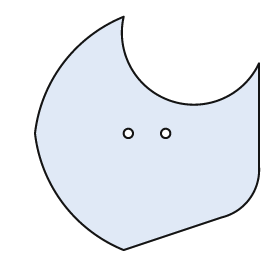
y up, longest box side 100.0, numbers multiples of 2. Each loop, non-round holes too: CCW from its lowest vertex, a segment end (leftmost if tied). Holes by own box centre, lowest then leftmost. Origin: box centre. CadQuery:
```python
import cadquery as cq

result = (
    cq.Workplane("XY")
    .moveTo(-10.0, -50.0)
    .lineTo(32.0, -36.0)
    .threePointArc((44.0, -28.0), (48.0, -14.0))
    .lineTo(48.0, 30.0)
    .threePointArc((10.0, 14.0), (-10.0, 50.0))
    .threePointArc((-36.0, 30.0), (-48.0, 0.0))
    .threePointArc((-36.0, -30.0), (-10.0, -50.0))
    .close()
    .moveTo(-8.0, 0.0)
    .circle(2.0)
    .moveTo(8.0, 0.0)
    .circle(2.0)
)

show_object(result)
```